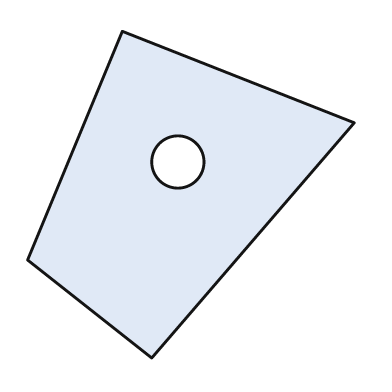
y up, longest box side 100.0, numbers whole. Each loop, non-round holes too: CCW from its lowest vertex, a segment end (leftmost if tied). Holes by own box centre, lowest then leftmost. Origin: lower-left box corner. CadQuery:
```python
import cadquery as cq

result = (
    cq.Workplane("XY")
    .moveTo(38.0, 0.0)
    .lineTo(100.0, 72.0)
    .lineTo(29.0, 100.0)
    .lineTo(0.0, 30.0)
    .close()
    .moveTo(46.0, 60.0)
    .circle(8.0)
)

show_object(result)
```